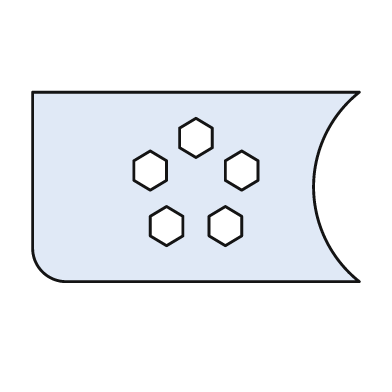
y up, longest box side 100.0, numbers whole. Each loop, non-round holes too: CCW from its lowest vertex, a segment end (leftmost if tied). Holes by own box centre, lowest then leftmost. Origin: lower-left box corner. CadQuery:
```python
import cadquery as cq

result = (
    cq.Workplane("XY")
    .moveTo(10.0, 0.0)
    .lineTo(100.0, 0.0)
    .threePointArc((86.0, 29.0), (100.0, 58.0))
    .lineTo(0.0, 58.0)
    .lineTo(0.0, 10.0)
    .threePointArc((3.0, 3.0), (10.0, 0.0))
    .close()
    .moveTo(41.0, 11.0)
    .lineTo(46.0, 14.0)
    .lineTo(46.0, 20.0)
    .lineTo(41.0, 23.0)
    .lineTo(36.0, 20.0)
    .lineTo(36.0, 14.0)
    .close()
    .moveTo(59.0, 11.0)
    .lineTo(64.0, 14.0)
    .lineTo(64.0, 20.0)
    .lineTo(59.0, 23.0)
    .lineTo(54.0, 20.0)
    .lineTo(54.0, 14.0)
    .close()
    .moveTo(36.0, 28.0)
    .lineTo(41.0, 31.0)
    .lineTo(41.0, 37.0)
    .lineTo(36.0, 40.0)
    .lineTo(31.0, 37.0)
    .lineTo(31.0, 31.0)
    .close()
    .moveTo(64.0, 28.0)
    .lineTo(69.0, 31.0)
    .lineTo(69.0, 37.0)
    .lineTo(64.0, 40.0)
    .lineTo(59.0, 37.0)
    .lineTo(59.0, 31.0)
    .close()
    .moveTo(50.0, 38.0)
    .lineTo(55.0, 41.0)
    .lineTo(55.0, 47.0)
    .lineTo(50.0, 50.0)
    .lineTo(45.0, 47.0)
    .lineTo(45.0, 41.0)
    .close()
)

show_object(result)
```